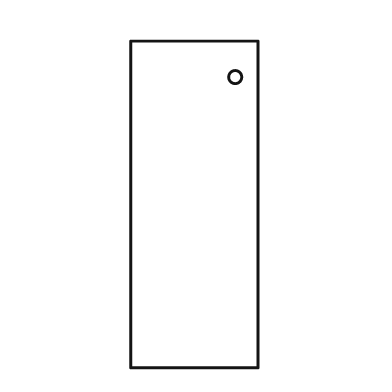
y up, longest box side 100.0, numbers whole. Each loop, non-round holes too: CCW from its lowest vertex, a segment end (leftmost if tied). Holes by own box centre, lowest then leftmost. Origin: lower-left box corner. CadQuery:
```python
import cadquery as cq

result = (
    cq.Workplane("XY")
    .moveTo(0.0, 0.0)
    .lineTo(39.0, 0.0)
    .lineTo(39.0, 100.0)
    .lineTo(0.0, 100.0)
    .close()
    .moveTo(32.0, 89.0)
    .circle(2.0)
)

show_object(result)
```